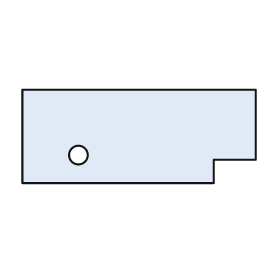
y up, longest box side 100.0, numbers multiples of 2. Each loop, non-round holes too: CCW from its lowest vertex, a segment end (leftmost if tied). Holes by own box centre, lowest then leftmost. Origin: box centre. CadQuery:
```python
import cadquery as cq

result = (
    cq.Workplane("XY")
    .moveTo(-50.0, -20.0)
    .lineTo(32.0, -20.0)
    .lineTo(32.0, -10.0)
    .lineTo(50.0, -10.0)
    .lineTo(50.0, 20.0)
    .lineTo(-50.0, 20.0)
    .close()
    .moveTo(-26.0, -8.0)
    .circle(4.0)
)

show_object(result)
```